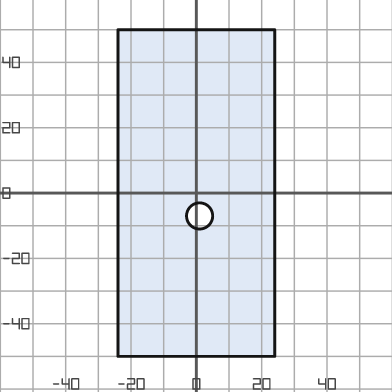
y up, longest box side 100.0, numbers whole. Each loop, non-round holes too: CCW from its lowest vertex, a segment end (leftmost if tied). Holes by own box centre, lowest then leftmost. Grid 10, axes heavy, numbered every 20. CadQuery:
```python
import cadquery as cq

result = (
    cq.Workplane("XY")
    .moveTo(-24.0, -50.0)
    .lineTo(24.0, -50.0)
    .lineTo(24.0, 50.0)
    .lineTo(-24.0, 50.0)
    .close()
    .moveTo(1.0, -7.0)
    .circle(4.0)
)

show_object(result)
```